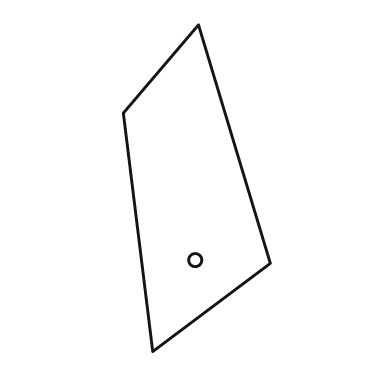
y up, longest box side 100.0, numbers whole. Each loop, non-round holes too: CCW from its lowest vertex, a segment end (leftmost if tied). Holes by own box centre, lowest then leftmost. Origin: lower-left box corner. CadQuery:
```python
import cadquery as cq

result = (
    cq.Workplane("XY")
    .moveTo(9.0, 0.0)
    .lineTo(45.0, 27.0)
    .lineTo(23.0, 100.0)
    .lineTo(0.0, 73.0)
    .close()
    .moveTo(22.0, 28.0)
    .circle(2.0)
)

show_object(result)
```